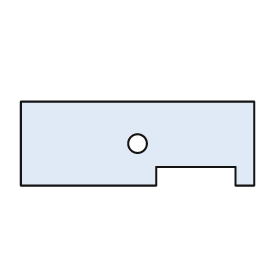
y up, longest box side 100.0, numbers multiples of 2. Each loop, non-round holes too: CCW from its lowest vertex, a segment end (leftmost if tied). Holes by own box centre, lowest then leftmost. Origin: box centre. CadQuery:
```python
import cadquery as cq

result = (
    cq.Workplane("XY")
    .moveTo(-50.0, -18.0)
    .lineTo(8.0, -18.0)
    .lineTo(8.0, -10.0)
    .lineTo(42.0, -10.0)
    .lineTo(42.0, -18.0)
    .lineTo(50.0, -18.0)
    .lineTo(50.0, 18.0)
    .lineTo(-50.0, 18.0)
    .close()
    .moveTo(0.0, 0.0)
    .circle(4.0)
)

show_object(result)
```